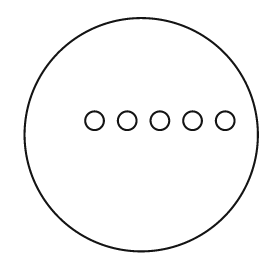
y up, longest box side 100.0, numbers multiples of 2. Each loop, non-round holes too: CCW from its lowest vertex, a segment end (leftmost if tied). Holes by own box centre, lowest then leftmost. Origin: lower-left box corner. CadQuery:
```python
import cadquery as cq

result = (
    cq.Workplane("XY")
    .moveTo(50.0, 50.0)
    .circle(50.0)
    .moveTo(30.0, 56.0)
    .circle(4.0)
    .moveTo(44.0, 56.0)
    .circle(4.0)
    .moveTo(58.0, 56.0)
    .circle(4.0)
    .moveTo(72.0, 56.0)
    .circle(4.0)
    .moveTo(86.0, 56.0)
    .circle(4.0)
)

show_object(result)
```